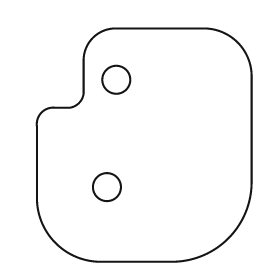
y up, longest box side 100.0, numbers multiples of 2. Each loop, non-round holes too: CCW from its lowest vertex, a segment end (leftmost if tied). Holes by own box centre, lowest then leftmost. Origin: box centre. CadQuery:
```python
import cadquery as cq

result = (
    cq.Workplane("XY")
    .moveTo(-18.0, -50.0)
    .lineTo(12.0, -50.0)
    .threePointArc((36.0, -40.0), (46.0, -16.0))
    .lineTo(46.0, 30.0)
    .threePointArc((40.0, 44.0), (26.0, 50.0))
    .lineTo(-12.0, 50.0)
    .threePointArc((-22.0, 46.0), (-26.0, 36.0))
    .lineTo(-26.0, 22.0)
    .threePointArc((-28.0, 18.0), (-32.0, 16.0))
    .lineTo(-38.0, 16.0)
    .threePointArc((-44.0, 14.0), (-46.0, 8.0))
    .lineTo(-46.0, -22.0)
    .threePointArc((-38.0, -42.0), (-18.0, -50.0))
    .close()
    .moveTo(-16.0, -18.0)
    .circle(6.0)
    .moveTo(-12.0, 28.0)
    .circle(6.0)
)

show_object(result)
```